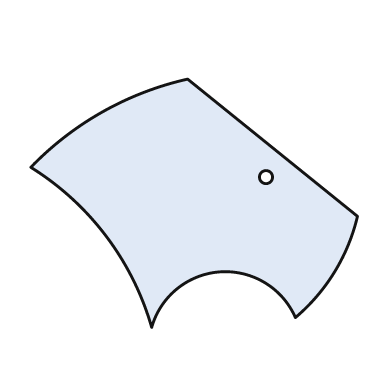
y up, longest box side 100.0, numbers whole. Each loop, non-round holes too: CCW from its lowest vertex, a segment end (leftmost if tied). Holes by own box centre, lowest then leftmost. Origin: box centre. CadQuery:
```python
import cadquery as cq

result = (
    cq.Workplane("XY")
    .moveTo(-13.0, -38.0)
    .threePointArc((8.0, -21.0), (31.0, -35.0))
    .threePointArc((43.0, -21.0), (50.0, -4.0))
    .lineTo(-2.0, 38.0)
    .threePointArc((-28.0, 28.0), (-50.0, 11.0))
    .threePointArc((-27.0, -10.0), (-13.0, -38.0))
    .close()
    .moveTo(22.0, 8.0)
    .circle(2.0)
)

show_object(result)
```